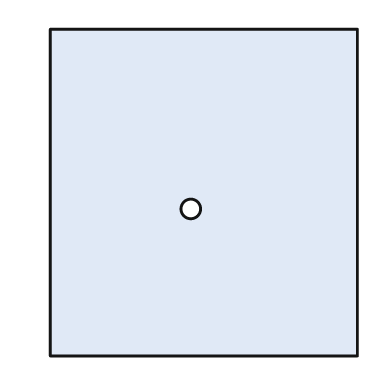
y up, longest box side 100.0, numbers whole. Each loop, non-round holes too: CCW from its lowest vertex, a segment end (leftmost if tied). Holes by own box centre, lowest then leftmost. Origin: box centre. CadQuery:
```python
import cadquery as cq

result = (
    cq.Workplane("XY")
    .moveTo(-47.0, -50.0)
    .lineTo(47.0, -50.0)
    .lineTo(47.0, 50.0)
    .lineTo(-47.0, 50.0)
    .close()
    .moveTo(-4.0, -5.0)
    .circle(3.0)
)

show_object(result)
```